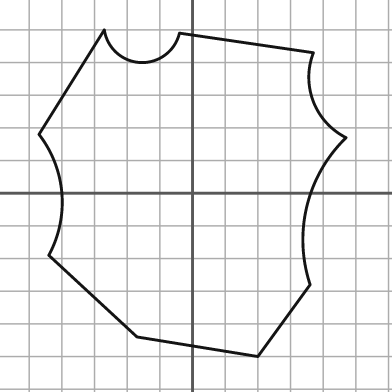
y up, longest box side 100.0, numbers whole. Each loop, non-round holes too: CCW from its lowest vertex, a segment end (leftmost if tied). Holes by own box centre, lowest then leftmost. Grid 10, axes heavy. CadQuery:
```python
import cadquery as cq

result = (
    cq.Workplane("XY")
    .moveTo(20.0, -50.0)
    .lineTo(36.0, -28.0)
    .threePointArc((35.0, -4.0), (47.0, 17.0))
    .threePointArc((37.0, 28.0), (37.0, 43.0))
    .lineTo(-4.0, 49.0)
    .threePointArc((-16.0, 40.0), (-27.0, 50.0))
    .lineTo(-47.0, 18.0)
    .threePointArc((-40.0, 0.0), (-44.0, -19.0))
    .lineTo(-17.0, -44.0)
    .close()
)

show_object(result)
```